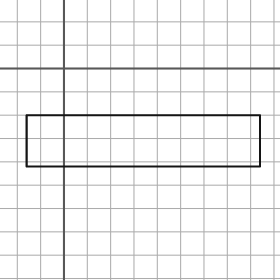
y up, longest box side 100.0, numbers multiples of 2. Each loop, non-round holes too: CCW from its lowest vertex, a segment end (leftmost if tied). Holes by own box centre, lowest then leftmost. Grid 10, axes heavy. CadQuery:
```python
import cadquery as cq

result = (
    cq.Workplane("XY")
    .moveTo(-16.0, -42.0)
    .lineTo(84.0, -42.0)
    .lineTo(84.0, -20.0)
    .lineTo(-16.0, -20.0)
    .close()
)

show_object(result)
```